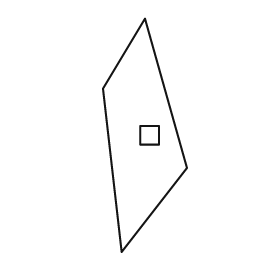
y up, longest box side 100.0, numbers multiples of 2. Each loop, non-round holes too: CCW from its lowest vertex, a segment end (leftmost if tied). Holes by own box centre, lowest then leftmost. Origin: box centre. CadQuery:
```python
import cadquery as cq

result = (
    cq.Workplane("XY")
    .moveTo(-10.0, -50.0)
    .lineTo(18.0, -14.0)
    .lineTo(0.0, 50.0)
    .lineTo(-18.0, 20.0)
    .close()
    .moveTo(-2.0, -4.0)
    .lineTo(6.0, -4.0)
    .lineTo(6.0, 4.0)
    .lineTo(-2.0, 4.0)
    .close()
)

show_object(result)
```